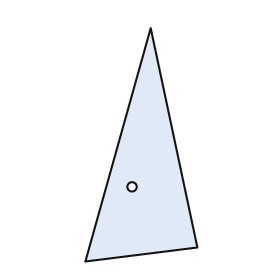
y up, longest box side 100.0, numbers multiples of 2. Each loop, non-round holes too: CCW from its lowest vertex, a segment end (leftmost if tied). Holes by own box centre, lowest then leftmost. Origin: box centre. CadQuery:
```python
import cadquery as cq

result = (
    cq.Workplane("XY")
    .moveTo(-24.0, -50.0)
    .lineTo(24.0, -44.0)
    .lineTo(4.0, 50.0)
    .close()
    .moveTo(-4.0, -18.0)
    .circle(2.0)
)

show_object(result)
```